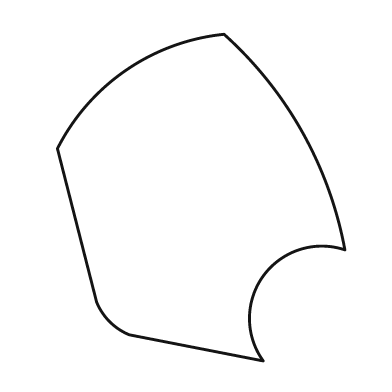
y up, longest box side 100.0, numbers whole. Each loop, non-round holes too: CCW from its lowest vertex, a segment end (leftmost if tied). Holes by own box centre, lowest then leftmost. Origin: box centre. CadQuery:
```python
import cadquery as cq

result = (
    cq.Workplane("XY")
    .moveTo(19.0, -50.0)
    .threePointArc((19.0, -24.0), (44.0, -16.0))
    .threePointArc((31.0, 20.0), (7.0, 50.0))
    .threePointArc((-23.0, 39.0), (-44.0, 15.0))
    .lineTo(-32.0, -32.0)
    .threePointArc((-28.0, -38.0), (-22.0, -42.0))
    .close()
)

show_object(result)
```